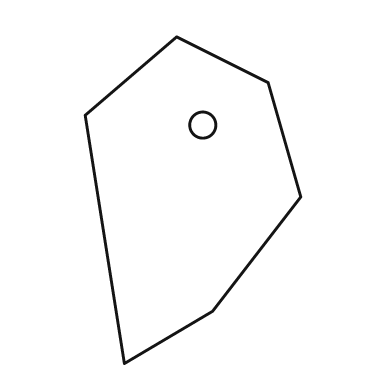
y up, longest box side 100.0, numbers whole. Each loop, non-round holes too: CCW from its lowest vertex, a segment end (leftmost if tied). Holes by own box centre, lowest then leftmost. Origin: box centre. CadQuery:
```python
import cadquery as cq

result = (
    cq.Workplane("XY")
    .moveTo(-21.0, -50.0)
    .lineTo(6.0, -34.0)
    .lineTo(33.0, 1.0)
    .lineTo(23.0, 36.0)
    .lineTo(-5.0, 50.0)
    .lineTo(-33.0, 26.0)
    .close()
    .moveTo(3.0, 23.0)
    .circle(4.0)
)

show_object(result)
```